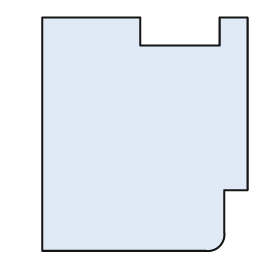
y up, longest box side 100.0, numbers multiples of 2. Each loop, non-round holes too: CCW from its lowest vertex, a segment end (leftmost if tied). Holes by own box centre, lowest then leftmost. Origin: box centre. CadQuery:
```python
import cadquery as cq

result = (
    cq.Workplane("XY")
    .moveTo(-44.0, -50.0)
    .lineTo(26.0, -50.0)
    .threePointArc((32.0, -48.0), (34.0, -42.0))
    .lineTo(34.0, -24.0)
    .lineTo(44.0, -24.0)
    .lineTo(44.0, 50.0)
    .lineTo(32.0, 50.0)
    .lineTo(32.0, 38.0)
    .lineTo(-2.0, 38.0)
    .lineTo(-2.0, 50.0)
    .lineTo(-44.0, 50.0)
    .close()
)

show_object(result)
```